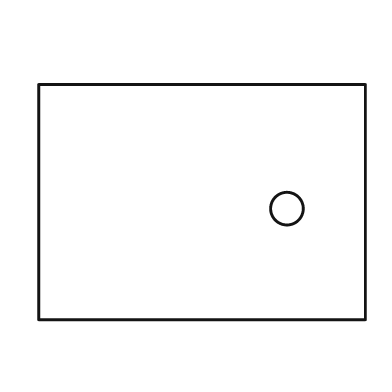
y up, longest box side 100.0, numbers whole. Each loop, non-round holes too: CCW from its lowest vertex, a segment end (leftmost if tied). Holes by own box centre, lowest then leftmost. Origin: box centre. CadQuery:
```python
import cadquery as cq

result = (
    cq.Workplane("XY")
    .moveTo(-50.0, -36.0)
    .lineTo(50.0, -36.0)
    .lineTo(50.0, 36.0)
    .lineTo(-50.0, 36.0)
    .close()
    .moveTo(26.0, -2.0)
    .circle(5.0)
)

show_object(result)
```